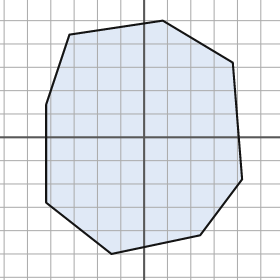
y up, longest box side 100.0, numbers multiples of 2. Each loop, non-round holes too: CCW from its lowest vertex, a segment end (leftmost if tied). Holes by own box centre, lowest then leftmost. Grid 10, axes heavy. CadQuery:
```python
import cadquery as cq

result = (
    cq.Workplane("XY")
    .moveTo(-14.0, -50.0)
    .lineTo(24.0, -42.0)
    .lineTo(42.0, -18.0)
    .lineTo(38.0, 32.0)
    .lineTo(8.0, 50.0)
    .lineTo(-32.0, 44.0)
    .lineTo(-42.0, 14.0)
    .lineTo(-42.0, -28.0)
    .close()
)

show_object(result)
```